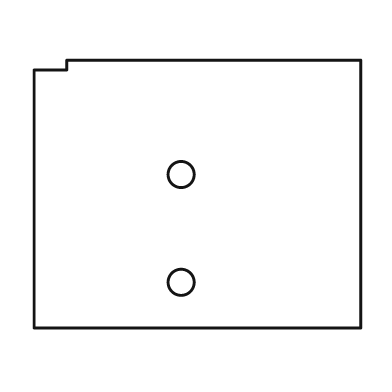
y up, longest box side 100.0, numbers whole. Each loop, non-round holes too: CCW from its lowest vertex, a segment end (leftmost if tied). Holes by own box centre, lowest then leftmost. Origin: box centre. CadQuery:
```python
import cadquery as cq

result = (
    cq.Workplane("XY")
    .moveTo(-50.0, -41.0)
    .lineTo(50.0, -41.0)
    .lineTo(50.0, 41.0)
    .lineTo(-40.0, 41.0)
    .lineTo(-40.0, 38.0)
    .lineTo(-50.0, 38.0)
    .close()
    .moveTo(-5.0, -27.0)
    .circle(4.0)
    .moveTo(-5.0, 6.0)
    .circle(4.0)
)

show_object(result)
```